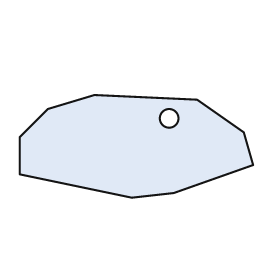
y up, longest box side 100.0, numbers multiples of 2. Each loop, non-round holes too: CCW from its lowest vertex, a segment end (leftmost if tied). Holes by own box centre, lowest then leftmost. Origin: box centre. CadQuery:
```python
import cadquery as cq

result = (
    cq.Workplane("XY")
    .moveTo(-2.0, -22.0)
    .lineTo(16.0, -20.0)
    .lineTo(50.0, -8.0)
    .lineTo(46.0, 6.0)
    .lineTo(26.0, 20.0)
    .lineTo(-18.0, 22.0)
    .lineTo(-38.0, 16.0)
    .lineTo(-50.0, 4.0)
    .lineTo(-50.0, -12.0)
    .close()
    .moveTo(14.0, 12.0)
    .circle(4.0)
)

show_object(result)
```